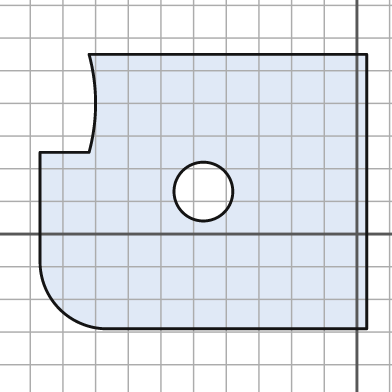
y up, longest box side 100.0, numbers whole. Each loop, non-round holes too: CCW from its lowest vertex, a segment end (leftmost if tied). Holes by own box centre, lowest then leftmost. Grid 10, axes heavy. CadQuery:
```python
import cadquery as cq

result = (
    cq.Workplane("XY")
    .moveTo(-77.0, -29.0)
    .lineTo(3.0, -29.0)
    .lineTo(3.0, 55.0)
    .lineTo(-82.0, 55.0)
    .threePointArc((-80.0, 40.0), (-82.0, 25.0))
    .lineTo(-97.0, 25.0)
    .lineTo(-97.0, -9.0)
    .threePointArc((-91.0, -23.0), (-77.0, -29.0))
    .close()
    .moveTo(-47.0, 13.0)
    .circle(9.0)
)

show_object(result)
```